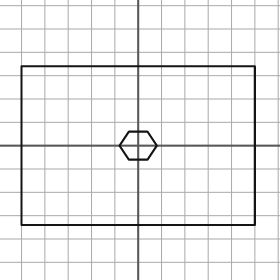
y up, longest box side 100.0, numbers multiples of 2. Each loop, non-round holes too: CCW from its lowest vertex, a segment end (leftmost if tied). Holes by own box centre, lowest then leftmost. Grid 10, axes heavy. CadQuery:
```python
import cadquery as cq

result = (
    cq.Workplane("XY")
    .moveTo(-50.0, -34.0)
    .lineTo(50.0, -34.0)
    .lineTo(50.0, 34.0)
    .lineTo(-50.0, 34.0)
    .close()
    .moveTo(-4.0, -6.0)
    .lineTo(4.0, -6.0)
    .lineTo(8.0, 0.0)
    .lineTo(4.0, 6.0)
    .lineTo(-4.0, 6.0)
    .lineTo(-8.0, 0.0)
    .close()
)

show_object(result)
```